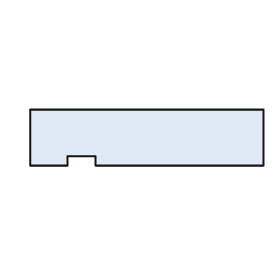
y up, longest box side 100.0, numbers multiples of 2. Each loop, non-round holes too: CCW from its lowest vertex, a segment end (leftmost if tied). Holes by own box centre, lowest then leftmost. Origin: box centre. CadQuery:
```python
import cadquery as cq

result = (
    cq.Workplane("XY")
    .moveTo(-50.0, -12.0)
    .lineTo(-34.0, -12.0)
    .lineTo(-34.0, -8.0)
    .lineTo(-22.0, -8.0)
    .lineTo(-22.0, -12.0)
    .lineTo(50.0, -12.0)
    .lineTo(50.0, 12.0)
    .lineTo(-50.0, 12.0)
    .close()
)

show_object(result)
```